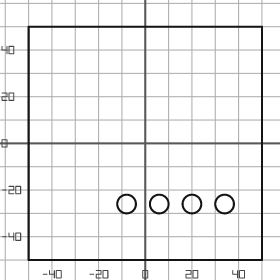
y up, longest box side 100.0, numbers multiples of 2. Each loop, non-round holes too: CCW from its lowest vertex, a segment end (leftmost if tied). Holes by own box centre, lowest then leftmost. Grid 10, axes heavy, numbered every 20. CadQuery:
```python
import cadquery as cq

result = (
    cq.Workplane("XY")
    .moveTo(-50.0, -50.0)
    .lineTo(50.0, -50.0)
    .lineTo(50.0, 50.0)
    .lineTo(-50.0, 50.0)
    .close()
    .moveTo(-8.0, -26.0)
    .circle(4.0)
    .moveTo(6.0, -26.0)
    .circle(4.0)
    .moveTo(20.0, -26.0)
    .circle(4.0)
    .moveTo(34.0, -26.0)
    .circle(4.0)
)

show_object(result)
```